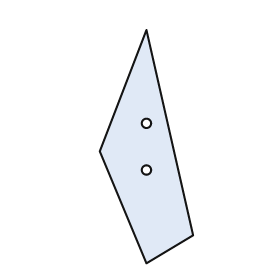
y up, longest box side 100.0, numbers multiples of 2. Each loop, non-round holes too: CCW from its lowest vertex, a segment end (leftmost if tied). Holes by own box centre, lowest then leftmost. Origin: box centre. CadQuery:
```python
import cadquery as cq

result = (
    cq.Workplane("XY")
    .moveTo(0.0, -50.0)
    .lineTo(20.0, -38.0)
    .lineTo(0.0, 50.0)
    .lineTo(-20.0, -2.0)
    .close()
    .moveTo(0.0, -10.0)
    .circle(2.0)
    .moveTo(0.0, 10.0)
    .circle(2.0)
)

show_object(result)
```